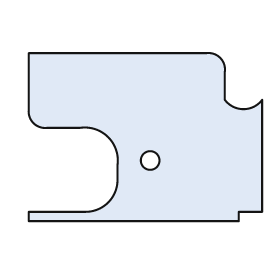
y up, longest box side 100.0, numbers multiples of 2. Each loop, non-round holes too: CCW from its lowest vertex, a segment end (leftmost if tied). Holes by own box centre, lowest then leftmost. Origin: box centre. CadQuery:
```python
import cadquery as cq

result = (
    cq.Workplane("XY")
    .moveTo(-50.0, -36.0)
    .lineTo(40.0, -36.0)
    .lineTo(40.0, -32.0)
    .lineTo(50.0, -32.0)
    .lineTo(50.0, 16.0)
    .threePointArc((42.0, 12.0), (34.0, 16.0))
    .lineTo(34.0, 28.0)
    .threePointArc((32.0, 34.0), (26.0, 36.0))
    .lineTo(-50.0, 36.0)
    .lineTo(-50.0, 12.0)
    .threePointArc((-48.0, 6.0), (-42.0, 4.0))
    .lineTo(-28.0, 4.0)
    .threePointArc((-16.0, 0.0), (-12.0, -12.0))
    .lineTo(-12.0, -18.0)
    .threePointArc((-16.0, -28.0), (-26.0, -32.0))
    .lineTo(-50.0, -32.0)
    .close()
    .moveTo(2.0, -10.0)
    .circle(4.0)
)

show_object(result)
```